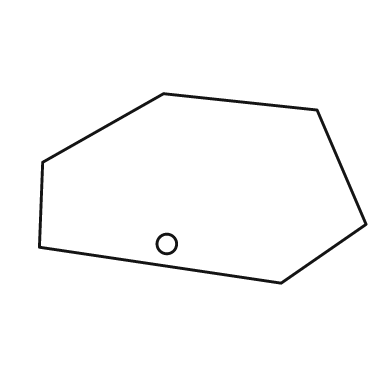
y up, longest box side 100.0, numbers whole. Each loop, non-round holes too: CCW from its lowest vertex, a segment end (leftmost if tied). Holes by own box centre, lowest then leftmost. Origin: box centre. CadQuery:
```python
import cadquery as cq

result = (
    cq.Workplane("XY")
    .moveTo(24.0, -29.0)
    .lineTo(50.0, -11.0)
    .lineTo(35.0, 24.0)
    .lineTo(-12.0, 29.0)
    .lineTo(-49.0, 8.0)
    .lineTo(-50.0, -18.0)
    .close()
    .moveTo(-11.0, -17.0)
    .circle(3.0)
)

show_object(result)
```